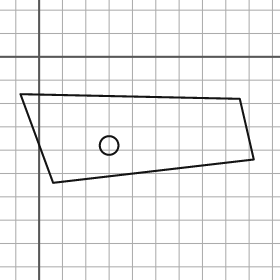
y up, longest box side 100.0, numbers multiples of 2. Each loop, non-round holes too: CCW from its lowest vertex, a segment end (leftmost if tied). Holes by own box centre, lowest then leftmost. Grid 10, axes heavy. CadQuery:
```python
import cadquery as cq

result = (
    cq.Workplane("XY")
    .moveTo(6.0, -54.0)
    .lineTo(92.0, -44.0)
    .lineTo(86.0, -18.0)
    .lineTo(-8.0, -16.0)
    .close()
    .moveTo(30.0, -38.0)
    .circle(4.0)
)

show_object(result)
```